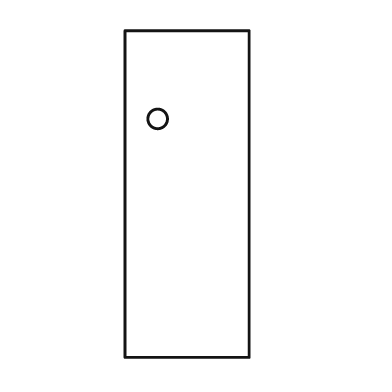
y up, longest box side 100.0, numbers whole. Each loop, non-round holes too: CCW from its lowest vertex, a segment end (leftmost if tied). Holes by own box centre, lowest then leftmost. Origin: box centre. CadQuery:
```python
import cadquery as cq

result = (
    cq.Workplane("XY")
    .moveTo(-19.0, -50.0)
    .lineTo(19.0, -50.0)
    .lineTo(19.0, 50.0)
    .lineTo(-19.0, 50.0)
    .close()
    .moveTo(-9.0, 23.0)
    .circle(3.0)
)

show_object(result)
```